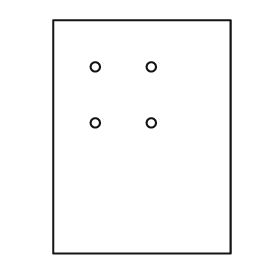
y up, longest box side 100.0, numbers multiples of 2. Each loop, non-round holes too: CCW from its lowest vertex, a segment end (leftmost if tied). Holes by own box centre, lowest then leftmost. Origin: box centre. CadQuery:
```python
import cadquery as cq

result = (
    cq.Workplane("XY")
    .moveTo(-38.0, -50.0)
    .lineTo(38.0, -50.0)
    .lineTo(38.0, 50.0)
    .lineTo(-38.0, 50.0)
    .close()
    .moveTo(-20.0, 6.0)
    .circle(2.0)
    .moveTo(4.0, 6.0)
    .circle(2.0)
    .moveTo(-20.0, 30.0)
    .circle(2.0)
    .moveTo(4.0, 30.0)
    .circle(2.0)
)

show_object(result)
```